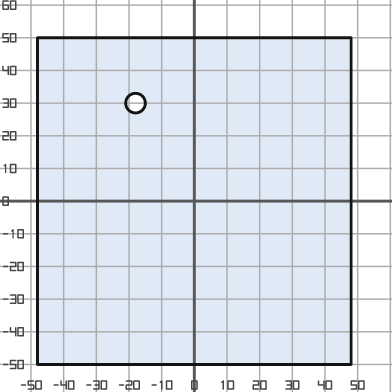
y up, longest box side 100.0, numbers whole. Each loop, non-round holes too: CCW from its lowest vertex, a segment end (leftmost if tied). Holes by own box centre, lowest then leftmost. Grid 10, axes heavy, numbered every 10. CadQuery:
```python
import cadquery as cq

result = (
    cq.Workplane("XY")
    .moveTo(-48.0, -50.0)
    .lineTo(48.0, -50.0)
    .lineTo(48.0, 50.0)
    .lineTo(-48.0, 50.0)
    .close()
    .moveTo(-18.0, 30.0)
    .circle(3.0)
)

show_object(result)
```